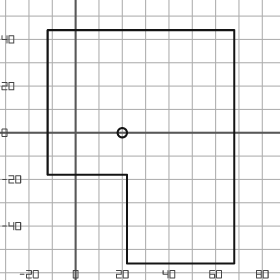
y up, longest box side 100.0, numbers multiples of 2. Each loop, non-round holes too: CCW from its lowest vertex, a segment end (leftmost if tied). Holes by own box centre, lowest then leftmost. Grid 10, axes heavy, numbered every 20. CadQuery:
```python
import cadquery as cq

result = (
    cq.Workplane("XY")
    .moveTo(22.0, -56.0)
    .lineTo(68.0, -56.0)
    .lineTo(68.0, 44.0)
    .lineTo(-12.0, 44.0)
    .lineTo(-12.0, -18.0)
    .lineTo(22.0, -18.0)
    .close()
    .moveTo(20.0, 0.0)
    .circle(2.0)
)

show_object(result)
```